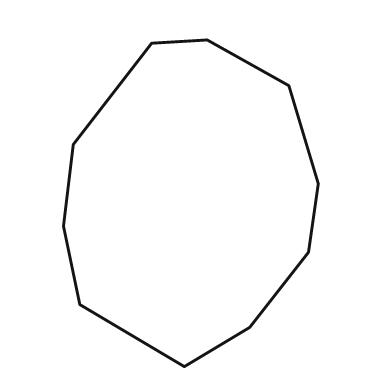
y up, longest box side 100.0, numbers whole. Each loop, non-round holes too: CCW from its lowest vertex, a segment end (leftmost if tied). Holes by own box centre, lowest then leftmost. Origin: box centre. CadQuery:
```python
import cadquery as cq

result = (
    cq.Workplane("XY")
    .moveTo(-2.0, -50.0)
    .lineTo(18.0, -38.0)
    .lineTo(36.0, -15.0)
    .lineTo(39.0, 6.0)
    .lineTo(30.0, 36.0)
    .lineTo(5.0, 50.0)
    .lineTo(-12.0, 49.0)
    .lineTo(-36.0, 18.0)
    .lineTo(-39.0, -7.0)
    .lineTo(-34.0, -31.0)
    .close()
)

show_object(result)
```